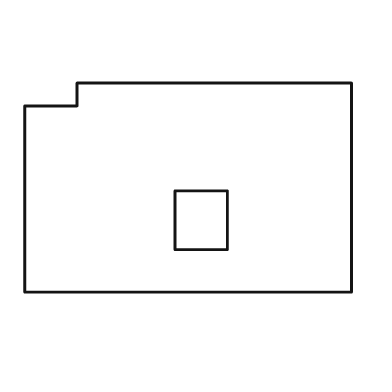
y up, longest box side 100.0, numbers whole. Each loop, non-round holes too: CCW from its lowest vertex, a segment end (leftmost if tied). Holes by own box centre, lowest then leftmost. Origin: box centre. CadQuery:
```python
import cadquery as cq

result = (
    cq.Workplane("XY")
    .moveTo(-50.0, -32.0)
    .lineTo(50.0, -32.0)
    .lineTo(50.0, 32.0)
    .lineTo(-34.0, 32.0)
    .lineTo(-34.0, 25.0)
    .lineTo(-50.0, 25.0)
    .close()
    .moveTo(-4.0, -19.0)
    .lineTo(12.0, -19.0)
    .lineTo(12.0, -1.0)
    .lineTo(-4.0, -1.0)
    .close()
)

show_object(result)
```